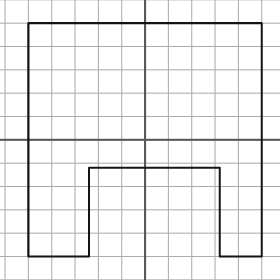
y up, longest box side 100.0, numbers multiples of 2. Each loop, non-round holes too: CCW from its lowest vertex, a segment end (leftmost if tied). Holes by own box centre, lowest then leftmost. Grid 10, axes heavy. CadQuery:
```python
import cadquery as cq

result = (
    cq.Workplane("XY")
    .moveTo(-50.0, -50.0)
    .lineTo(-24.0, -50.0)
    .lineTo(-24.0, -12.0)
    .lineTo(32.0, -12.0)
    .lineTo(32.0, -50.0)
    .lineTo(50.0, -50.0)
    .lineTo(50.0, 50.0)
    .lineTo(-50.0, 50.0)
    .close()
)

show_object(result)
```